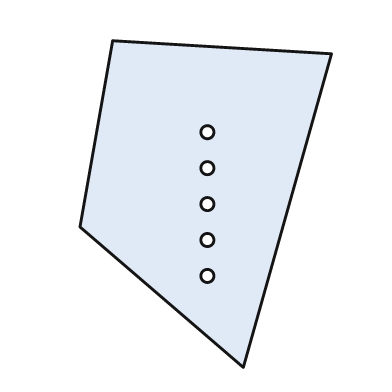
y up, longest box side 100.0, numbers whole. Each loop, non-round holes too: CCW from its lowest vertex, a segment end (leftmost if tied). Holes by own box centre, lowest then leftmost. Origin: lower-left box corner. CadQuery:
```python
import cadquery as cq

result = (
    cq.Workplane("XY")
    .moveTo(50.0, 0.0)
    .lineTo(77.0, 96.0)
    .lineTo(10.0, 100.0)
    .lineTo(0.0, 43.0)
    .close()
    .moveTo(39.0, 28.0)
    .circle(2.0)
    .moveTo(39.0, 39.0)
    .circle(2.0)
    .moveTo(39.0, 50.0)
    .circle(2.0)
    .moveTo(39.0, 61.0)
    .circle(2.0)
    .moveTo(39.0, 72.0)
    .circle(2.0)
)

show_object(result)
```